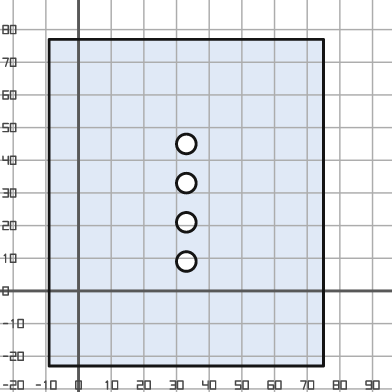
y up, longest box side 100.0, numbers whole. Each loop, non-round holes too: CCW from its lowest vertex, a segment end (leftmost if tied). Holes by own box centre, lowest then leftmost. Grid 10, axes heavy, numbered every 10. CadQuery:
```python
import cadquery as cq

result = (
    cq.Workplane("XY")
    .moveTo(-9.0, -23.0)
    .lineTo(75.0, -23.0)
    .lineTo(75.0, 77.0)
    .lineTo(-9.0, 77.0)
    .close()
    .moveTo(33.0, 9.0)
    .circle(3.0)
    .moveTo(33.0, 21.0)
    .circle(3.0)
    .moveTo(33.0, 33.0)
    .circle(3.0)
    .moveTo(33.0, 45.0)
    .circle(3.0)
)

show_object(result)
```